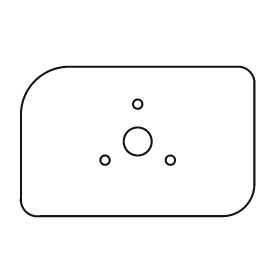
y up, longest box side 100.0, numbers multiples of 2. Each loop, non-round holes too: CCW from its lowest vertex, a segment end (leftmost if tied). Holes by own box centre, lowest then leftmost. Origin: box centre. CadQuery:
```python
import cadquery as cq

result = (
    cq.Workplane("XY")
    .moveTo(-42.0, -32.0)
    .lineTo(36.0, -32.0)
    .threePointArc((46.0, -28.0), (50.0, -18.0))
    .lineTo(50.0, 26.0)
    .threePointArc((48.0, 30.0), (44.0, 32.0))
    .lineTo(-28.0, 32.0)
    .threePointArc((-44.0, 26.0), (-50.0, 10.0))
    .lineTo(-50.0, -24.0)
    .threePointArc((-48.0, -30.0), (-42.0, -32.0))
    .close()
    .moveTo(-14.0, -8.0)
    .circle(2.0)
    .moveTo(14.0, -8.0)
    .circle(2.0)
    .moveTo(0.0, 0.0)
    .circle(6.0)
    .moveTo(0.0, 16.0)
    .circle(2.0)
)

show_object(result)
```